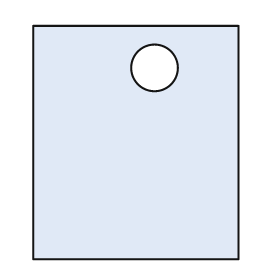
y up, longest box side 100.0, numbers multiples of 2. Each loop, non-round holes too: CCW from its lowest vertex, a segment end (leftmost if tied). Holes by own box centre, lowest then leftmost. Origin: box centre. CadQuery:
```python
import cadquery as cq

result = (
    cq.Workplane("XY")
    .moveTo(-44.0, -50.0)
    .lineTo(44.0, -50.0)
    .lineTo(44.0, 50.0)
    .lineTo(-44.0, 50.0)
    .close()
    .moveTo(8.0, 32.0)
    .circle(10.0)
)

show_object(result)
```